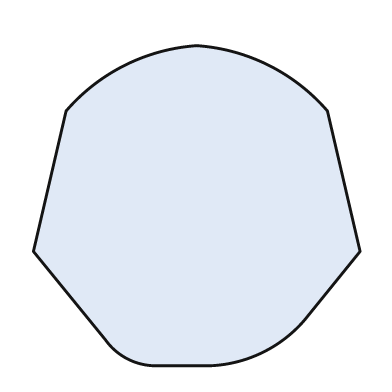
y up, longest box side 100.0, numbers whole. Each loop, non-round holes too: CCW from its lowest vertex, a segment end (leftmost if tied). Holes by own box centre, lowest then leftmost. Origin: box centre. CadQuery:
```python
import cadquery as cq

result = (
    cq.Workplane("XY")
    .moveTo(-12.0, -49.0)
    .lineTo(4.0, -49.0)
    .threePointArc((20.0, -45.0), (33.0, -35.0))
    .lineTo(50.0, -14.0)
    .lineTo(40.0, 29.0)
    .threePointArc((22.0, 43.0), (0.0, 49.0))
    .threePointArc((-22.0, 43.0), (-40.0, 29.0))
    .lineTo(-50.0, -14.0)
    .lineTo(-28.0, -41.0)
    .threePointArc((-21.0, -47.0), (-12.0, -49.0))
    .close()
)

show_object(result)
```